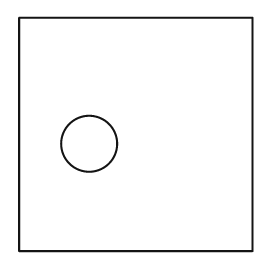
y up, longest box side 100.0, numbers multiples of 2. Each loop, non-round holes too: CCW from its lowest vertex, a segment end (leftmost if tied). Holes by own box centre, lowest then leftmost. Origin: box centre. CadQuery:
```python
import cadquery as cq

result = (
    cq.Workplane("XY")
    .moveTo(-50.0, -50.0)
    .lineTo(50.0, -50.0)
    .lineTo(50.0, 50.0)
    .lineTo(-50.0, 50.0)
    .close()
    .moveTo(-20.0, -4.0)
    .circle(12.0)
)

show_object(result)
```